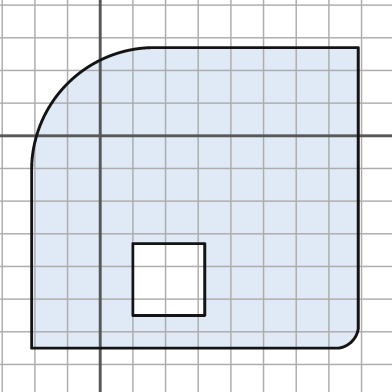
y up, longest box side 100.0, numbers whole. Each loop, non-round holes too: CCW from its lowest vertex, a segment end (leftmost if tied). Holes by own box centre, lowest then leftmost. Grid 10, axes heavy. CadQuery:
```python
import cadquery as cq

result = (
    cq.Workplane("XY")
    .moveTo(-21.0, -65.0)
    .lineTo(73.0, -65.0)
    .threePointArc((77.0, -63.0), (79.0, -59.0))
    .lineTo(79.0, 27.0)
    .lineTo(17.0, 27.0)
    .threePointArc((-10.0, 16.0), (-21.0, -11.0))
    .close()
    .moveTo(10.0, -55.0)
    .lineTo(32.0, -55.0)
    .lineTo(32.0, -33.0)
    .lineTo(10.0, -33.0)
    .close()
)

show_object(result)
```